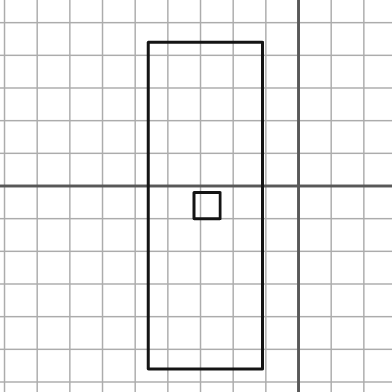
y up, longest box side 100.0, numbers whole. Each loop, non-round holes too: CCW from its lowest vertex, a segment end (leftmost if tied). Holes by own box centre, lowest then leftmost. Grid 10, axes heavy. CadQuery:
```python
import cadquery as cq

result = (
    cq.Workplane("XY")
    .moveTo(-46.0, -56.0)
    .lineTo(-11.0, -56.0)
    .lineTo(-11.0, 44.0)
    .lineTo(-46.0, 44.0)
    .close()
    .moveTo(-32.0, -10.0)
    .lineTo(-24.0, -10.0)
    .lineTo(-24.0, -2.0)
    .lineTo(-32.0, -2.0)
    .close()
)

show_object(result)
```